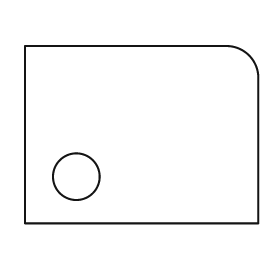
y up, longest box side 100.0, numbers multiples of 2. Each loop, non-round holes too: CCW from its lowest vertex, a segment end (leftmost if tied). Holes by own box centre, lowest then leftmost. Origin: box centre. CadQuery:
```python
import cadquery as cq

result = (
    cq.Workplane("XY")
    .moveTo(-50.0, -38.0)
    .lineTo(50.0, -38.0)
    .lineTo(50.0, 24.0)
    .threePointArc((46.0, 34.0), (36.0, 38.0))
    .lineTo(-50.0, 38.0)
    .close()
    .moveTo(-28.0, -18.0)
    .circle(10.0)
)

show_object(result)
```